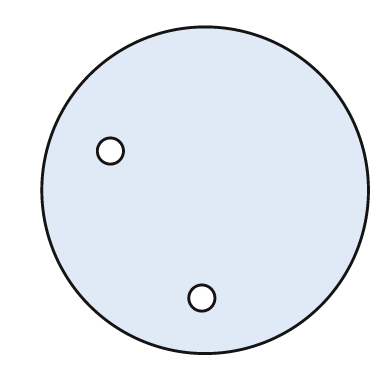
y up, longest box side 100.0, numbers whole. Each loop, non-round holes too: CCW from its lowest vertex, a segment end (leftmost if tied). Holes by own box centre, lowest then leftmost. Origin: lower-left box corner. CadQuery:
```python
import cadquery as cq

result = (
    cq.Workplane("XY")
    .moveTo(50.0, 50.0)
    .circle(50.0)
    .moveTo(49.0, 17.0)
    .circle(4.0)
    .moveTo(21.0, 62.0)
    .circle(4.0)
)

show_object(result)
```